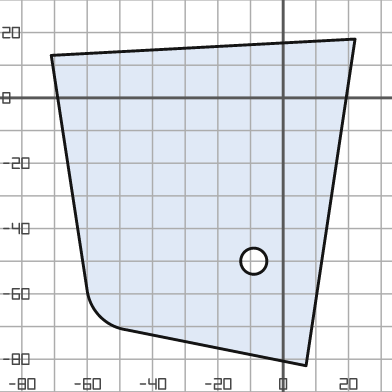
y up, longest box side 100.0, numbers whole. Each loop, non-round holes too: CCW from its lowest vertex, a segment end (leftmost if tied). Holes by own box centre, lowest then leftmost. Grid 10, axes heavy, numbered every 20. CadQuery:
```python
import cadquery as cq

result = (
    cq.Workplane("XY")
    .moveTo(7.0, -82.0)
    .lineTo(22.0, 18.0)
    .lineTo(-71.0, 13.0)
    .lineTo(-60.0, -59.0)
    .threePointArc((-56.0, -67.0), (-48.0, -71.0))
    .close()
    .moveTo(-9.0, -50.0)
    .circle(4.0)
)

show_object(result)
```